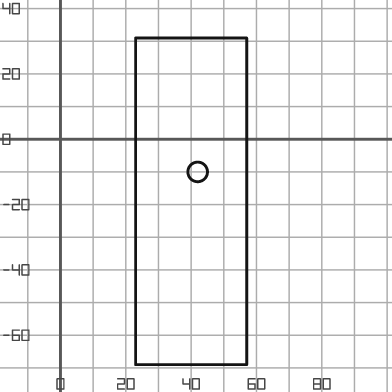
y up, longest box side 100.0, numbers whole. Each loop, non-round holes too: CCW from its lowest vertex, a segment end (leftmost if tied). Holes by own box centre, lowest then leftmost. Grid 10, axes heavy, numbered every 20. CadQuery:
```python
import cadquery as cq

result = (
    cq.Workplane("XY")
    .moveTo(23.0, -69.0)
    .lineTo(57.0, -69.0)
    .lineTo(57.0, 31.0)
    .lineTo(23.0, 31.0)
    .close()
    .moveTo(42.0, -10.0)
    .circle(3.0)
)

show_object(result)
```